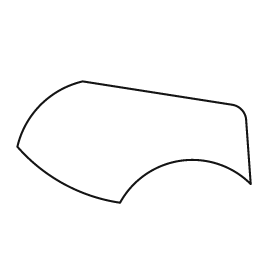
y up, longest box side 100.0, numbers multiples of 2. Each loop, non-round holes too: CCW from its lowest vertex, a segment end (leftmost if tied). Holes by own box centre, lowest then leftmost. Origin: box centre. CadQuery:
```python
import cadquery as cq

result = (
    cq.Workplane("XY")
    .moveTo(-6.0, -26.0)
    .threePointArc((20.0, -8.0), (50.0, -18.0))
    .lineTo(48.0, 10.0)
    .threePointArc((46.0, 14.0), (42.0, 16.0))
    .lineTo(-22.0, 26.0)
    .threePointArc((-40.0, 16.0), (-50.0, -2.0))
    .threePointArc((-30.0, -18.0), (-6.0, -26.0))
    .close()
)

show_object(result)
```